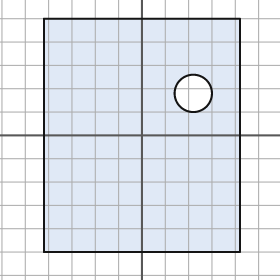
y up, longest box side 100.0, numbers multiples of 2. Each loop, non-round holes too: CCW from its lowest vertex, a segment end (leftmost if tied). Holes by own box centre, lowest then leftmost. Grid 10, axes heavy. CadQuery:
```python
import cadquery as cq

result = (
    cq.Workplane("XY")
    .moveTo(-42.0, -50.0)
    .lineTo(42.0, -50.0)
    .lineTo(42.0, 50.0)
    .lineTo(-42.0, 50.0)
    .close()
    .moveTo(22.0, 18.0)
    .circle(8.0)
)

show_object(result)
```